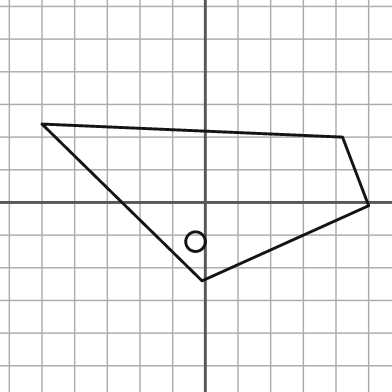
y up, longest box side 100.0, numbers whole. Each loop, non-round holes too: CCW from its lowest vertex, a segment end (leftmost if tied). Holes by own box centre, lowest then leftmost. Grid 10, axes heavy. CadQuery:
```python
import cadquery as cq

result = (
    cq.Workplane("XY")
    .moveTo(-1.0, -24.0)
    .lineTo(50.0, -1.0)
    .lineTo(42.0, 20.0)
    .lineTo(-50.0, 24.0)
    .close()
    .moveTo(-3.0, -12.0)
    .circle(3.0)
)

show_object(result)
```